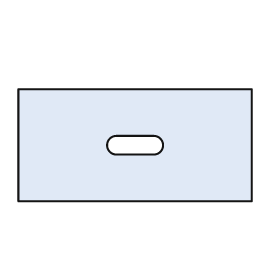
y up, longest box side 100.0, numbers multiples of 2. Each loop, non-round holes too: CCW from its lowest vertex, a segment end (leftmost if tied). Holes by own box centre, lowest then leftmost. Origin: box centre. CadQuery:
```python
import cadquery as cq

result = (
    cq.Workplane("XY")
    .moveTo(-50.0, -24.0)
    .lineTo(50.0, -24.0)
    .lineTo(50.0, 24.0)
    .lineTo(-50.0, 24.0)
    .close()
    .moveTo(-8.0, -4.0)
    .lineTo(8.0, -4.0)
    .threePointArc((12.0, 0.0), (8.0, 4.0))
    .lineTo(-8.0, 4.0)
    .threePointArc((-12.0, 0.0), (-8.0, -4.0))
    .close()
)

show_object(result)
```